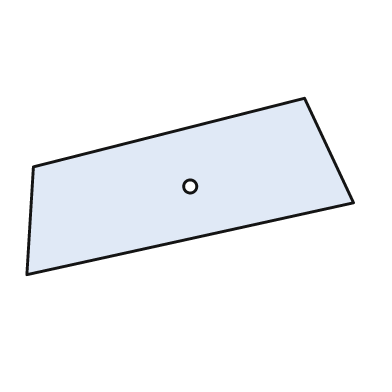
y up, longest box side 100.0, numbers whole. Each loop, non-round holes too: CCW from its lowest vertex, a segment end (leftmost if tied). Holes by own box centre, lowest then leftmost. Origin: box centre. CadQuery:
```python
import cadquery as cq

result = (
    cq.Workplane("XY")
    .moveTo(-50.0, -27.0)
    .lineTo(50.0, -5.0)
    .lineTo(35.0, 27.0)
    .lineTo(-48.0, 6.0)
    .close()
    .moveTo(0.0, 0.0)
    .circle(2.0)
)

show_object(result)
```